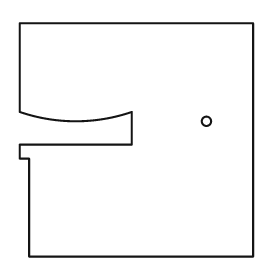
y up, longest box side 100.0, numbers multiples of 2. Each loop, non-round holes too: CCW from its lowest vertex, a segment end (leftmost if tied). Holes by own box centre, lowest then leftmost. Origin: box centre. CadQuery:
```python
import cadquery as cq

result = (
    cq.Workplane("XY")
    .moveTo(-46.0, -50.0)
    .lineTo(50.0, -50.0)
    .lineTo(50.0, 50.0)
    .lineTo(-50.0, 50.0)
    .lineTo(-50.0, 12.0)
    .threePointArc((-26.0, 8.0), (-2.0, 12.0))
    .lineTo(-2.0, -2.0)
    .lineTo(-50.0, -2.0)
    .lineTo(-50.0, -8.0)
    .lineTo(-46.0, -8.0)
    .close()
    .moveTo(30.0, 8.0)
    .circle(2.0)
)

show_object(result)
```